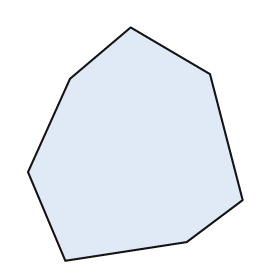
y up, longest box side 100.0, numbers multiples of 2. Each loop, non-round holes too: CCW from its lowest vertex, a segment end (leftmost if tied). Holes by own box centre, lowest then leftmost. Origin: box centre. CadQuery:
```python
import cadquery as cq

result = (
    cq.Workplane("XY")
    .moveTo(-30.0, -50.0)
    .lineTo(22.0, -42.0)
    .lineTo(46.0, -24.0)
    .lineTo(32.0, 30.0)
    .lineTo(-2.0, 50.0)
    .lineTo(-28.0, 28.0)
    .lineTo(-46.0, -12.0)
    .close()
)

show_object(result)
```